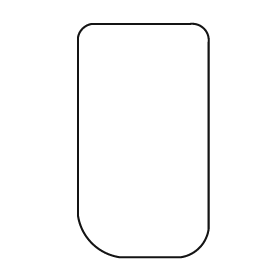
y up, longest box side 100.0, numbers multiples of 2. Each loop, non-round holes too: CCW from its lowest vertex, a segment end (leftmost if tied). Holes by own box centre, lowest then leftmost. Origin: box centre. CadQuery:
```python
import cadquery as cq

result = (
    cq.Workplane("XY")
    .moveTo(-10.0, -50.0)
    .lineTo(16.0, -50.0)
    .threePointArc((24.0, -46.0), (28.0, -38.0))
    .lineTo(28.0, 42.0)
    .threePointArc((26.0, 48.0), (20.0, 50.0))
    .lineTo(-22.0, 50.0)
    .threePointArc((-26.0, 48.0), (-28.0, 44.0))
    .lineTo(-28.0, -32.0)
    .threePointArc((-22.0, -44.0), (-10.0, -50.0))
    .close()
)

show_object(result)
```